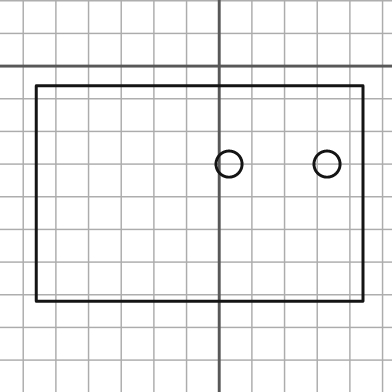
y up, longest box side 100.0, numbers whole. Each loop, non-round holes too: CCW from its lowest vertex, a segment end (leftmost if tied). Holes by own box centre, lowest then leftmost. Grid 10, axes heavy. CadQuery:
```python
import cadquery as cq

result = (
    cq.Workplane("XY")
    .moveTo(-56.0, -72.0)
    .lineTo(44.0, -72.0)
    .lineTo(44.0, -6.0)
    .lineTo(-56.0, -6.0)
    .close()
    .moveTo(3.0, -30.0)
    .circle(4.0)
    .moveTo(33.0, -30.0)
    .circle(4.0)
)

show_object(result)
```